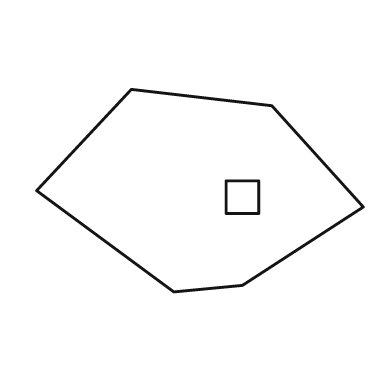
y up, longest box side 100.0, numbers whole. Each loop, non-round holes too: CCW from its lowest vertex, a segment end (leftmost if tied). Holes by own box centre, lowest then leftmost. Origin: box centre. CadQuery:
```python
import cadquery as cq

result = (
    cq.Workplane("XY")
    .moveTo(-8.0, -31.0)
    .lineTo(13.0, -29.0)
    .lineTo(50.0, -5.0)
    .lineTo(22.0, 26.0)
    .lineTo(-21.0, 31.0)
    .lineTo(-50.0, 0.0)
    .close()
    .moveTo(8.0, -7.0)
    .lineTo(18.0, -7.0)
    .lineTo(18.0, 3.0)
    .lineTo(8.0, 3.0)
    .close()
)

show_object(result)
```